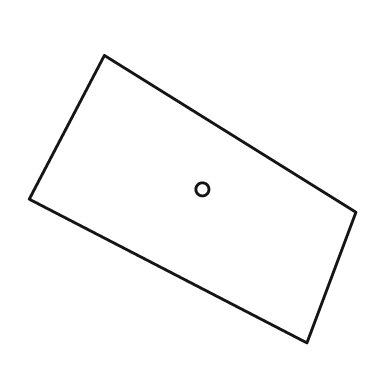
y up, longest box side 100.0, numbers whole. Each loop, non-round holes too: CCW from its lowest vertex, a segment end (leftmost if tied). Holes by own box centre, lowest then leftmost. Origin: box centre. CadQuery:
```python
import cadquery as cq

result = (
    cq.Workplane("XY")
    .moveTo(35.0, -44.0)
    .lineTo(50.0, -4.0)
    .lineTo(-27.0, 44.0)
    .lineTo(-50.0, 0.0)
    .close()
    .moveTo(3.0, 3.0)
    .circle(2.0)
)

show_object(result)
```